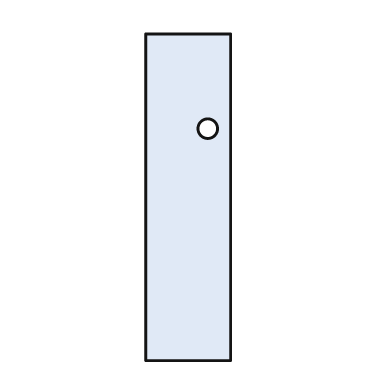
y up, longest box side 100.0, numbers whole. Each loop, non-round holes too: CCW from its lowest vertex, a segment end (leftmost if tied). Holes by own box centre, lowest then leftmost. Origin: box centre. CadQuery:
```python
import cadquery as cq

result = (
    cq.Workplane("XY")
    .moveTo(-13.0, -50.0)
    .lineTo(13.0, -50.0)
    .lineTo(13.0, 50.0)
    .lineTo(-13.0, 50.0)
    .close()
    .moveTo(6.0, 21.0)
    .circle(3.0)
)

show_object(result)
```